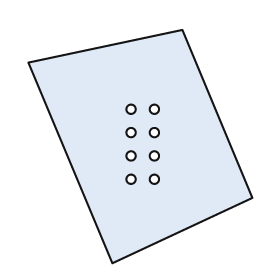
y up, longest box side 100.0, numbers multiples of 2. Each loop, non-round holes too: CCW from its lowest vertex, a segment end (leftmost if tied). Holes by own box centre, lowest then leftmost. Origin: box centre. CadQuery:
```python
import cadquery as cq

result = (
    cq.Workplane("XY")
    .moveTo(-12.0, -50.0)
    .lineTo(48.0, -22.0)
    .lineTo(18.0, 50.0)
    .lineTo(-48.0, 36.0)
    .close()
    .moveTo(-4.0, -14.0)
    .circle(2.0)
    .moveTo(6.0, -14.0)
    .circle(2.0)
    .moveTo(-4.0, -4.0)
    .circle(2.0)
    .moveTo(6.0, -4.0)
    .circle(2.0)
    .moveTo(-4.0, 6.0)
    .circle(2.0)
    .moveTo(6.0, 6.0)
    .circle(2.0)
    .moveTo(-4.0, 16.0)
    .circle(2.0)
    .moveTo(6.0, 16.0)
    .circle(2.0)
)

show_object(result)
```